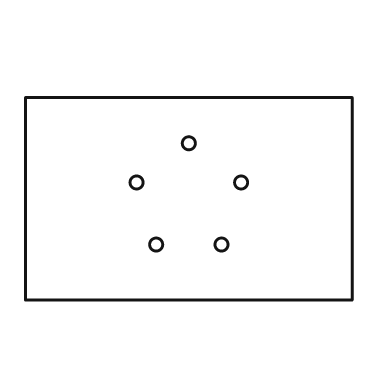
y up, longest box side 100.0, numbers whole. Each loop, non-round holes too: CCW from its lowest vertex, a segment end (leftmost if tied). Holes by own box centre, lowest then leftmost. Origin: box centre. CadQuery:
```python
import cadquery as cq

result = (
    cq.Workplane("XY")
    .moveTo(-50.0, -31.0)
    .lineTo(50.0, -31.0)
    .lineTo(50.0, 31.0)
    .lineTo(-50.0, 31.0)
    .close()
    .moveTo(-10.0, -14.0)
    .circle(2.0)
    .moveTo(10.0, -14.0)
    .circle(2.0)
    .moveTo(-16.0, 5.0)
    .circle(2.0)
    .moveTo(16.0, 5.0)
    .circle(2.0)
    .moveTo(0.0, 17.0)
    .circle(2.0)
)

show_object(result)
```